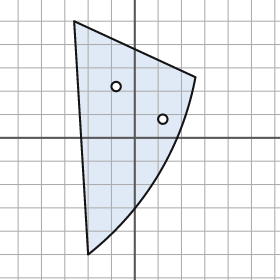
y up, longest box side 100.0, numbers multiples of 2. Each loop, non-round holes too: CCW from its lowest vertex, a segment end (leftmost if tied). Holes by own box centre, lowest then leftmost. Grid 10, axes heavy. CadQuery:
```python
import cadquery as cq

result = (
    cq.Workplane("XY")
    .moveTo(-20.0, -50.0)
    .threePointArc((10.0, -16.0), (26.0, 26.0))
    .lineTo(-26.0, 50.0)
    .close()
    .moveTo(12.0, 8.0)
    .circle(2.0)
    .moveTo(-8.0, 22.0)
    .circle(2.0)
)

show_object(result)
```